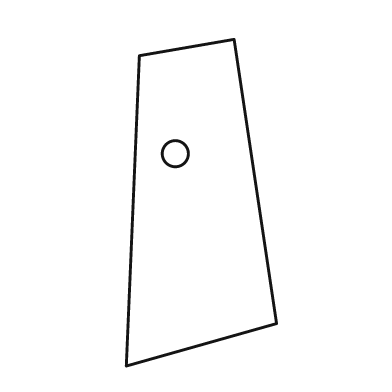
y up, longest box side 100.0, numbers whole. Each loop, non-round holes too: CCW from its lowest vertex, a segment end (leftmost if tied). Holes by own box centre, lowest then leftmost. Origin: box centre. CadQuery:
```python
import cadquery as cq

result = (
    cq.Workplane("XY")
    .moveTo(-23.0, -50.0)
    .lineTo(23.0, -37.0)
    .lineTo(10.0, 50.0)
    .lineTo(-19.0, 45.0)
    .close()
    .moveTo(-8.0, 15.0)
    .circle(4.0)
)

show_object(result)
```